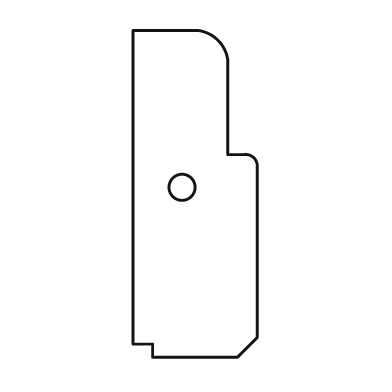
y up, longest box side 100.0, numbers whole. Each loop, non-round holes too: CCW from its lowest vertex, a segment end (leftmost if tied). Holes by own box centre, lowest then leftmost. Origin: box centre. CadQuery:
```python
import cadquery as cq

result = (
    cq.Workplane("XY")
    .moveTo(-13.0, -50.0)
    .lineTo(13.0, -50.0)
    .lineTo(19.0, -44.0)
    .lineTo(19.0, 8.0)
    .threePointArc((18.0, 11.0), (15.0, 12.0))
    .lineTo(10.0, 12.0)
    .lineTo(10.0, 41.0)
    .threePointArc((7.0, 47.0), (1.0, 50.0))
    .lineTo(-19.0, 50.0)
    .lineTo(-19.0, -46.0)
    .lineTo(-13.0, -46.0)
    .close()
    .moveTo(-4.0, 2.0)
    .circle(4.0)
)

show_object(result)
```